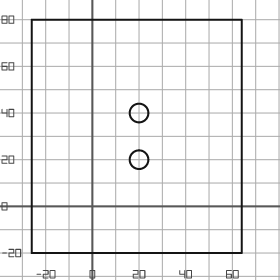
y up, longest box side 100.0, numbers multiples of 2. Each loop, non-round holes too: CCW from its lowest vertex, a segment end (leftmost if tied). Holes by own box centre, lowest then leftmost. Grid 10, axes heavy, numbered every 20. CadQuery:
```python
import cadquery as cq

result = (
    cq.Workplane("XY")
    .moveTo(-26.0, -20.0)
    .lineTo(64.0, -20.0)
    .lineTo(64.0, 80.0)
    .lineTo(-26.0, 80.0)
    .close()
    .moveTo(20.0, 20.0)
    .circle(4.0)
    .moveTo(20.0, 40.0)
    .circle(4.0)
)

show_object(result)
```